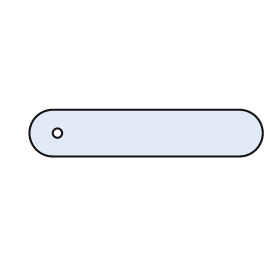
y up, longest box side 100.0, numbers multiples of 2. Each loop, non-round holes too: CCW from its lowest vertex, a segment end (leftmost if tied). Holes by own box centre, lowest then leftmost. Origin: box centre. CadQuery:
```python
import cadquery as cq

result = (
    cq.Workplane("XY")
    .moveTo(-40.0, -10.0)
    .lineTo(40.0, -10.0)
    .threePointArc((50.0, 0.0), (40.0, 10.0))
    .lineTo(-40.0, 10.0)
    .threePointArc((-50.0, 0.0), (-40.0, -10.0))
    .close()
    .moveTo(-38.0, 0.0)
    .circle(2.0)
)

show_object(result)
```